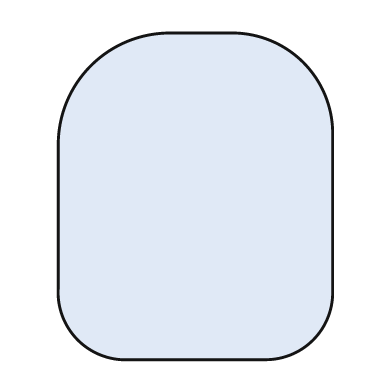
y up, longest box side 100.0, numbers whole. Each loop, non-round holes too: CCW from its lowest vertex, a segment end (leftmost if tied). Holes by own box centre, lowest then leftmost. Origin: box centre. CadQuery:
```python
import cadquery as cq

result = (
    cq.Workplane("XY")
    .moveTo(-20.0, -50.0)
    .lineTo(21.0, -50.0)
    .threePointArc((36.0, -44.0), (42.0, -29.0))
    .lineTo(42.0, 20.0)
    .threePointArc((33.0, 41.0), (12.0, 50.0))
    .lineTo(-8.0, 50.0)
    .threePointArc((-32.0, 40.0), (-42.0, 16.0))
    .lineTo(-42.0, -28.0)
    .threePointArc((-36.0, -44.0), (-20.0, -50.0))
    .close()
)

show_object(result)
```